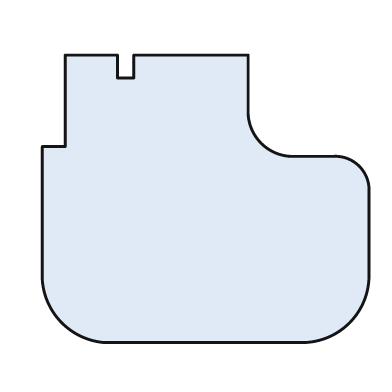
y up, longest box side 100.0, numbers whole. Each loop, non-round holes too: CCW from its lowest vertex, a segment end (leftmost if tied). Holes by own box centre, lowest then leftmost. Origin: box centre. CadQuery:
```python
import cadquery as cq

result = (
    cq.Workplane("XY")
    .moveTo(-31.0, -44.0)
    .lineTo(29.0, -44.0)
    .threePointArc((44.0, -38.0), (50.0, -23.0))
    .lineTo(50.0, 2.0)
    .threePointArc((47.0, 10.0), (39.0, 13.0))
    .lineTo(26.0, 13.0)
    .threePointArc((17.0, 17.0), (13.0, 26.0))
    .lineTo(13.0, 44.0)
    .lineTo(-22.0, 44.0)
    .lineTo(-22.0, 37.0)
    .lineTo(-27.0, 37.0)
    .lineTo(-27.0, 44.0)
    .lineTo(-43.0, 44.0)
    .lineTo(-43.0, 16.0)
    .lineTo(-50.0, 16.0)
    .lineTo(-50.0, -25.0)
    .threePointArc((-44.0, -38.0), (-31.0, -44.0))
    .close()
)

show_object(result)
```